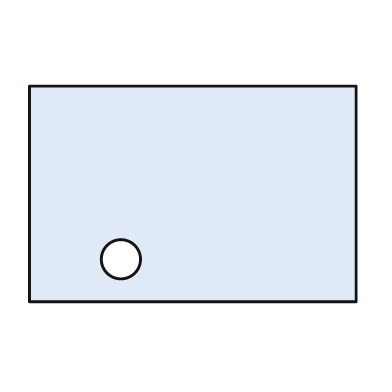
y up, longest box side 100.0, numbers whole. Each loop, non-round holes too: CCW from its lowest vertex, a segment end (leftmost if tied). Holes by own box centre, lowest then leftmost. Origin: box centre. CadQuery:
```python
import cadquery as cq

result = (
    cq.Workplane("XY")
    .moveTo(-50.0, -33.0)
    .lineTo(50.0, -33.0)
    .lineTo(50.0, 33.0)
    .lineTo(-50.0, 33.0)
    .close()
    .moveTo(-22.0, -20.0)
    .circle(6.0)
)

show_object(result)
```